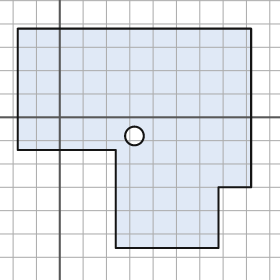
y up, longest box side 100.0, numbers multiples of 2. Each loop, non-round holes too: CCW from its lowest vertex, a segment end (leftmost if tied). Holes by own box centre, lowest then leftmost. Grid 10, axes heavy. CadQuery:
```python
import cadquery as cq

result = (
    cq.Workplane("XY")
    .moveTo(24.0, -56.0)
    .lineTo(68.0, -56.0)
    .lineTo(68.0, -30.0)
    .lineTo(82.0, -30.0)
    .lineTo(82.0, 38.0)
    .lineTo(-18.0, 38.0)
    .lineTo(-18.0, -14.0)
    .lineTo(24.0, -14.0)
    .close()
    .moveTo(32.0, -8.0)
    .circle(4.0)
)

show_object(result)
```